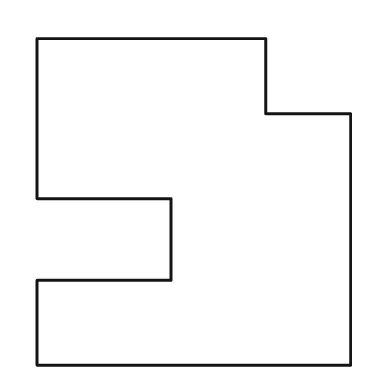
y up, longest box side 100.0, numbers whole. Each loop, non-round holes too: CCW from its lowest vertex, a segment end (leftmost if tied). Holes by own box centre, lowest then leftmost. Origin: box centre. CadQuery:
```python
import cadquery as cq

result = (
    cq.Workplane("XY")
    .moveTo(-48.0, -50.0)
    .lineTo(48.0, -50.0)
    .lineTo(48.0, 27.0)
    .lineTo(22.0, 27.0)
    .lineTo(22.0, 50.0)
    .lineTo(-48.0, 50.0)
    .lineTo(-48.0, 1.0)
    .lineTo(-7.0, 1.0)
    .lineTo(-7.0, -24.0)
    .lineTo(-48.0, -24.0)
    .close()
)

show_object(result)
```